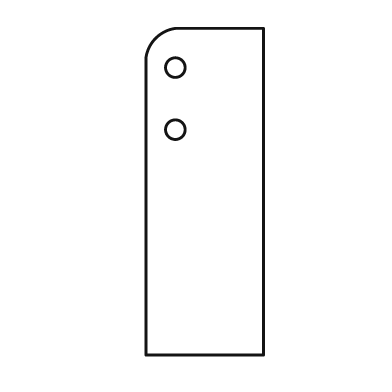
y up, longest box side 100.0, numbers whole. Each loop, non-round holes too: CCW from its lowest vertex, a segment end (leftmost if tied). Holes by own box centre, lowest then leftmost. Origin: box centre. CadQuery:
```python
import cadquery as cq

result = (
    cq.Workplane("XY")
    .moveTo(-18.0, -50.0)
    .lineTo(18.0, -50.0)
    .lineTo(18.0, 50.0)
    .lineTo(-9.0, 50.0)
    .threePointArc((-15.0, 47.0), (-18.0, 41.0))
    .close()
    .moveTo(-9.0, 19.0)
    .circle(3.0)
    .moveTo(-9.0, 38.0)
    .circle(3.0)
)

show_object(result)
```